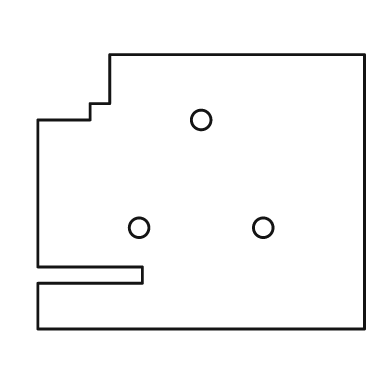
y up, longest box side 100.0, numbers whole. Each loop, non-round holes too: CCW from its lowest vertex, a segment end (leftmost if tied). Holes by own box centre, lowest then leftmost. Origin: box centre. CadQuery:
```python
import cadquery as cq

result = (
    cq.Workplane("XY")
    .moveTo(-50.0, -42.0)
    .lineTo(50.0, -42.0)
    .lineTo(50.0, 42.0)
    .lineTo(-28.0, 42.0)
    .lineTo(-28.0, 27.0)
    .lineTo(-34.0, 27.0)
    .lineTo(-34.0, 22.0)
    .lineTo(-50.0, 22.0)
    .lineTo(-50.0, -23.0)
    .lineTo(-18.0, -23.0)
    .lineTo(-18.0, -28.0)
    .lineTo(-50.0, -28.0)
    .close()
    .moveTo(-19.0, -11.0)
    .circle(3.0)
    .moveTo(19.0, -11.0)
    .circle(3.0)
    .moveTo(0.0, 22.0)
    .circle(3.0)
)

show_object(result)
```